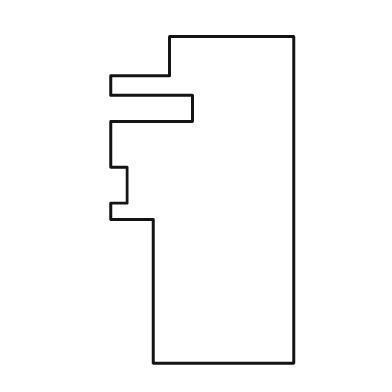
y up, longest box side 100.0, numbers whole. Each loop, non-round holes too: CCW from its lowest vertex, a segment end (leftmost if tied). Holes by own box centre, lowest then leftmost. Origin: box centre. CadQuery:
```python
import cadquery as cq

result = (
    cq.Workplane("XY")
    .moveTo(-15.0, -50.0)
    .lineTo(28.0, -50.0)
    .lineTo(28.0, 50.0)
    .lineTo(-10.0, 50.0)
    .lineTo(-10.0, 38.0)
    .lineTo(-28.0, 38.0)
    .lineTo(-28.0, 32.0)
    .lineTo(-3.0, 32.0)
    .lineTo(-3.0, 24.0)
    .lineTo(-28.0, 24.0)
    .lineTo(-28.0, 10.0)
    .lineTo(-23.0, 10.0)
    .lineTo(-23.0, -1.0)
    .lineTo(-28.0, -1.0)
    .lineTo(-28.0, -6.0)
    .lineTo(-15.0, -6.0)
    .close()
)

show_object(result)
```